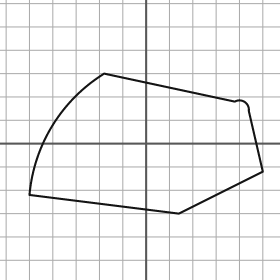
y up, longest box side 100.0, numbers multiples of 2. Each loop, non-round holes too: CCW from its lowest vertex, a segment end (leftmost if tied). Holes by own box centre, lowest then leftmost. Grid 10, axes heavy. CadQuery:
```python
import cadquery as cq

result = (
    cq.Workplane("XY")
    .moveTo(14.0, -30.0)
    .lineTo(50.0, -12.0)
    .lineTo(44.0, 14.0)
    .threePointArc((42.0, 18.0), (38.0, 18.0))
    .lineTo(-18.0, 30.0)
    .threePointArc((-40.0, 8.0), (-50.0, -22.0))
    .close()
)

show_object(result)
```